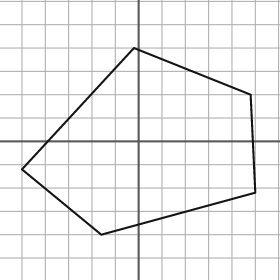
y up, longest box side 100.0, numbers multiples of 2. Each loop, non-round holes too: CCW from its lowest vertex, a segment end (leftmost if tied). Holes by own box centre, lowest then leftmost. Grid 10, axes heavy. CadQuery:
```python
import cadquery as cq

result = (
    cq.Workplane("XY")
    .moveTo(-16.0, -40.0)
    .lineTo(50.0, -22.0)
    .lineTo(48.0, 20.0)
    .lineTo(-2.0, 40.0)
    .lineTo(-50.0, -12.0)
    .close()
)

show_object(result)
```